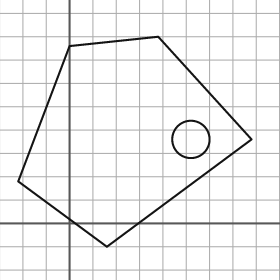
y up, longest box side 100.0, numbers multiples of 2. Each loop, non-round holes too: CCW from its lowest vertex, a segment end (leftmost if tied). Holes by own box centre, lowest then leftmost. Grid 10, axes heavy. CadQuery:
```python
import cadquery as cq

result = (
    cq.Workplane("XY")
    .moveTo(16.0, -10.0)
    .lineTo(78.0, 36.0)
    .lineTo(38.0, 80.0)
    .lineTo(0.0, 76.0)
    .lineTo(-22.0, 18.0)
    .close()
    .moveTo(52.0, 36.0)
    .circle(8.0)
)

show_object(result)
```